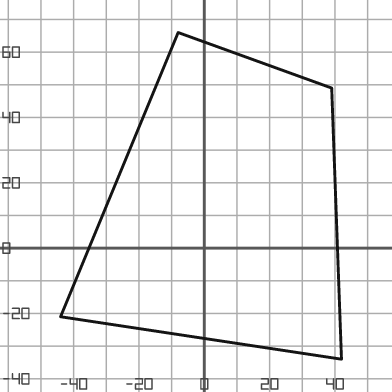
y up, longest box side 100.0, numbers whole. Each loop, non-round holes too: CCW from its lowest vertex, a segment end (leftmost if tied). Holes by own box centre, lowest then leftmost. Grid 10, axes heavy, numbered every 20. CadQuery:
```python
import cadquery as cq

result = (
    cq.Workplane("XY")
    .moveTo(42.0, -34.0)
    .lineTo(39.0, 49.0)
    .lineTo(-8.0, 66.0)
    .lineTo(-44.0, -21.0)
    .close()
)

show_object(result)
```